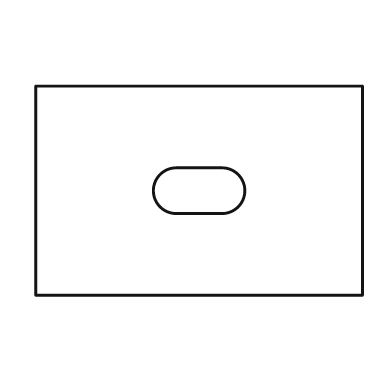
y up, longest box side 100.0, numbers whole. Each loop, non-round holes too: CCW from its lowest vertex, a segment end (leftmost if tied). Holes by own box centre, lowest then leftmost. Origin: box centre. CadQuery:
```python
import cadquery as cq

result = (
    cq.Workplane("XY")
    .moveTo(-50.0, -32.0)
    .lineTo(50.0, -32.0)
    .lineTo(50.0, 32.0)
    .lineTo(-50.0, 32.0)
    .close()
    .moveTo(-7.0, -7.0)
    .lineTo(7.0, -7.0)
    .threePointArc((14.0, 0.0), (7.0, 7.0))
    .lineTo(-7.0, 7.0)
    .threePointArc((-14.0, 0.0), (-7.0, -7.0))
    .close()
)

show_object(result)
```